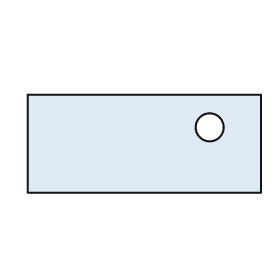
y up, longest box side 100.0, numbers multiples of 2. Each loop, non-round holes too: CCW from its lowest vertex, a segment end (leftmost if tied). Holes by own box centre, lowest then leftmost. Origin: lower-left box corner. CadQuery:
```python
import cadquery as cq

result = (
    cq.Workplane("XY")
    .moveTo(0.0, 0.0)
    .lineTo(100.0, 0.0)
    .lineTo(100.0, 42.0)
    .lineTo(0.0, 42.0)
    .close()
    .moveTo(78.0, 28.0)
    .circle(6.0)
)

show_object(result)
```